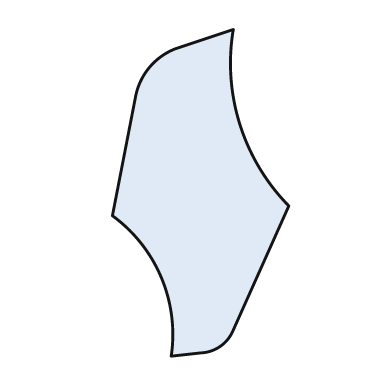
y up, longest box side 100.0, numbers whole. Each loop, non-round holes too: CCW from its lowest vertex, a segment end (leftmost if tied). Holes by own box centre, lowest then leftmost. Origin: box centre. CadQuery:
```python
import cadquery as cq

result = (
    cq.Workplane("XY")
    .moveTo(-9.0, -50.0)
    .lineTo(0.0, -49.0)
    .threePointArc((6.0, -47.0), (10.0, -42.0))
    .lineTo(27.0, -4.0)
    .threePointArc((12.0, 21.0), (10.0, 50.0))
    .lineTo(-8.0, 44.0)
    .threePointArc((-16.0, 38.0), (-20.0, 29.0))
    .lineTo(-27.0, -7.0)
    .threePointArc((-12.0, -26.0), (-9.0, -50.0))
    .close()
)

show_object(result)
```